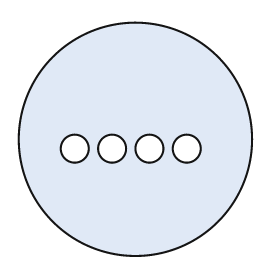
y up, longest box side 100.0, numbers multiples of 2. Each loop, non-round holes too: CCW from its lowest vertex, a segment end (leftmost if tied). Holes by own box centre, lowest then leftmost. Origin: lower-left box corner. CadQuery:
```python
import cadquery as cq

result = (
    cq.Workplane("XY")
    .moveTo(50.0, 50.0)
    .circle(50.0)
    .moveTo(24.0, 46.0)
    .circle(6.0)
    .moveTo(40.0, 46.0)
    .circle(6.0)
    .moveTo(56.0, 46.0)
    .circle(6.0)
    .moveTo(72.0, 46.0)
    .circle(6.0)
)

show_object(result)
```